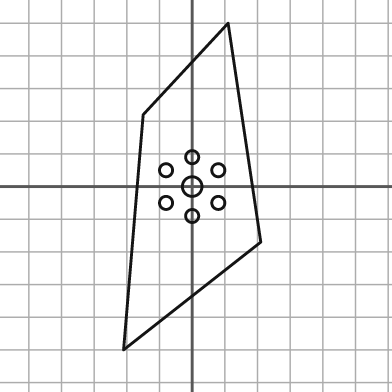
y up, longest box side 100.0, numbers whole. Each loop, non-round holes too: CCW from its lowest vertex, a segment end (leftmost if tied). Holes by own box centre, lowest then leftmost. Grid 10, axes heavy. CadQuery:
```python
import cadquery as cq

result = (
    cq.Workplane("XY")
    .moveTo(-21.0, -50.0)
    .lineTo(21.0, -17.0)
    .lineTo(11.0, 50.0)
    .lineTo(-15.0, 22.0)
    .close()
    .moveTo(0.0, -9.0)
    .circle(2.0)
    .moveTo(-8.0, -5.0)
    .circle(2.0)
    .moveTo(8.0, -5.0)
    .circle(2.0)
    .moveTo(0.0, 0.0)
    .circle(3.0)
    .moveTo(-8.0, 5.0)
    .circle(2.0)
    .moveTo(8.0, 5.0)
    .circle(2.0)
    .moveTo(0.0, 9.0)
    .circle(2.0)
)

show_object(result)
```